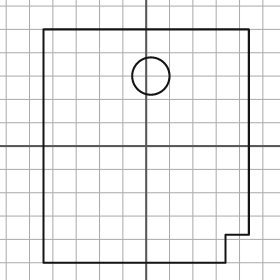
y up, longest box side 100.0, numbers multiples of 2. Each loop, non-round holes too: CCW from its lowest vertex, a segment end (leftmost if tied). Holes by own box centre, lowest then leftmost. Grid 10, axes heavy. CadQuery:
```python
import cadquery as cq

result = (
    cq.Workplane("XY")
    .moveTo(-44.0, -50.0)
    .lineTo(34.0, -50.0)
    .lineTo(34.0, -38.0)
    .lineTo(44.0, -38.0)
    .lineTo(44.0, 50.0)
    .lineTo(-44.0, 50.0)
    .close()
    .moveTo(2.0, 30.0)
    .circle(8.0)
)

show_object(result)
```